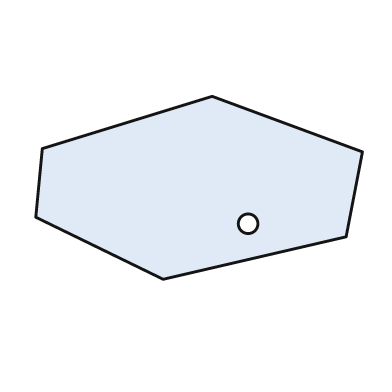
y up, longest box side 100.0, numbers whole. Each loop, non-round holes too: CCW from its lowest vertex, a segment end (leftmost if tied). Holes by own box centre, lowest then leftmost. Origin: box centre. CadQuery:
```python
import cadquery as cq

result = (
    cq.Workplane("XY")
    .moveTo(-11.0, -28.0)
    .lineTo(45.0, -15.0)
    .lineTo(50.0, 11.0)
    .lineTo(4.0, 28.0)
    .lineTo(-48.0, 12.0)
    .lineTo(-50.0, -9.0)
    .close()
    .moveTo(15.0, -11.0)
    .circle(3.0)
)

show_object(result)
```